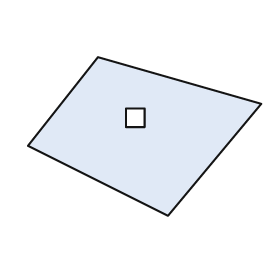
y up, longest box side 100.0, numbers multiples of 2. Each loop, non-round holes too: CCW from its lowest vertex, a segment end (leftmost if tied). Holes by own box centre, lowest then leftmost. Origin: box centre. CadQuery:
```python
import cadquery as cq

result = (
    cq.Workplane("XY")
    .moveTo(10.0, -34.0)
    .lineTo(50.0, 14.0)
    .lineTo(-20.0, 34.0)
    .lineTo(-50.0, -4.0)
    .close()
    .moveTo(-8.0, 4.0)
    .lineTo(0.0, 4.0)
    .lineTo(0.0, 12.0)
    .lineTo(-8.0, 12.0)
    .close()
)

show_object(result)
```